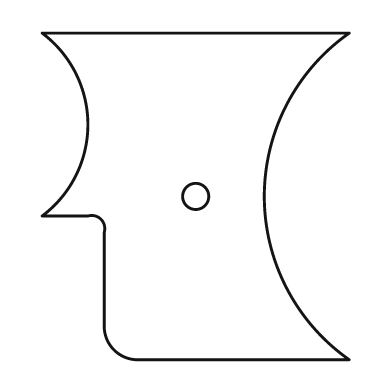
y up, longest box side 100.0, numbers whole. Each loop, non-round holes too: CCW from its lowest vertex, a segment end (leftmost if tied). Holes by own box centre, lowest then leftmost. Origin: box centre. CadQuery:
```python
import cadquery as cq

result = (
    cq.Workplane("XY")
    .moveTo(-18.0, -50.0)
    .lineTo(47.0, -50.0)
    .threePointArc((21.0, 0.0), (47.0, 50.0))
    .lineTo(-47.0, 50.0)
    .threePointArc((-33.0, 22.0), (-47.0, -6.0))
    .lineTo(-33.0, -6.0)
    .threePointArc((-29.0, -7.0), (-28.0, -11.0))
    .lineTo(-28.0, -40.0)
    .threePointArc((-25.0, -47.0), (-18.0, -50.0))
    .close()
    .moveTo(0.0, 0.0)
    .circle(4.0)
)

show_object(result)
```